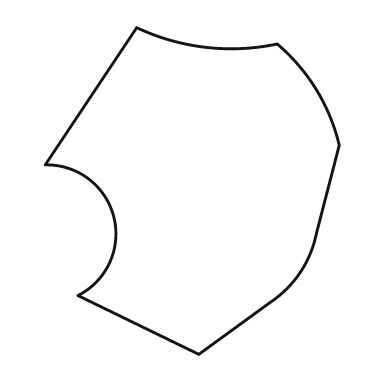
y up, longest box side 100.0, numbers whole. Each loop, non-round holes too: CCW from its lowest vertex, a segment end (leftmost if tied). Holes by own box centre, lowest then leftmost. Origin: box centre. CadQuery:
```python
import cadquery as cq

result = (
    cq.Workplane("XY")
    .moveTo(2.0, -50.0)
    .lineTo(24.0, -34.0)
    .threePointArc((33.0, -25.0), (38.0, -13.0))
    .lineTo(45.0, 14.0)
    .threePointArc((38.0, 31.0), (26.0, 45.0))
    .threePointArc((4.0, 44.0), (-17.0, 50.0))
    .lineTo(-45.0, 8.0)
    .threePointArc((-24.0, -8.0), (-35.0, -32.0))
    .close()
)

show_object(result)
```